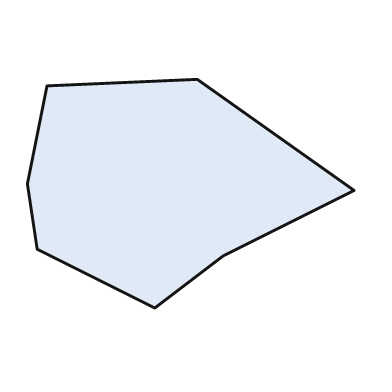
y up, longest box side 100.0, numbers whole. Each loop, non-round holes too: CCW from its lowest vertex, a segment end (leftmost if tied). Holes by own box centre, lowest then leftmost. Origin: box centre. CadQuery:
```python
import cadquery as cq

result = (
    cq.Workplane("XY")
    .moveTo(-11.0, -35.0)
    .lineTo(10.0, -19.0)
    .lineTo(50.0, 1.0)
    .lineTo(2.0, 35.0)
    .lineTo(-44.0, 33.0)
    .lineTo(-50.0, 3.0)
    .lineTo(-47.0, -17.0)
    .close()
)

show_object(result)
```